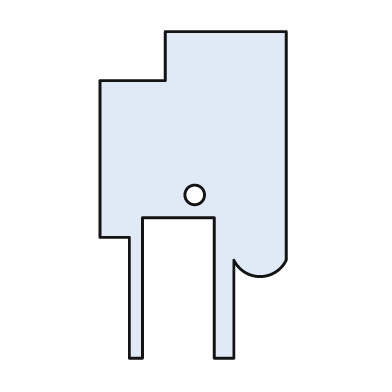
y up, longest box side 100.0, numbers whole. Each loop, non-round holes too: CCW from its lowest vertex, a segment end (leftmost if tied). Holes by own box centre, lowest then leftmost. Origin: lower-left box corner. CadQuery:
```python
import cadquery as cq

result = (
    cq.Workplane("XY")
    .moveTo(9.0, 0.0)
    .lineTo(13.0, 0.0)
    .lineTo(13.0, 43.0)
    .lineTo(35.0, 43.0)
    .lineTo(35.0, 0.0)
    .lineTo(41.0, 0.0)
    .lineTo(41.0, 30.0)
    .threePointArc((49.0, 25.0), (57.0, 30.0))
    .lineTo(57.0, 100.0)
    .lineTo(20.0, 100.0)
    .lineTo(20.0, 85.0)
    .lineTo(0.0, 85.0)
    .lineTo(0.0, 37.0)
    .lineTo(9.0, 37.0)
    .close()
    .moveTo(29.0, 50.0)
    .circle(3.0)
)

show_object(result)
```